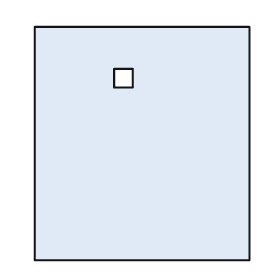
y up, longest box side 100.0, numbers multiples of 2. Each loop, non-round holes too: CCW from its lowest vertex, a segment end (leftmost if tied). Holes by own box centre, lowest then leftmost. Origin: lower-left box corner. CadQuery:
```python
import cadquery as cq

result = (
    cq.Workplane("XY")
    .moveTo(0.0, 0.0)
    .lineTo(92.0, 0.0)
    .lineTo(92.0, 100.0)
    .lineTo(0.0, 100.0)
    .close()
    .moveTo(34.0, 74.0)
    .lineTo(42.0, 74.0)
    .lineTo(42.0, 82.0)
    .lineTo(34.0, 82.0)
    .close()
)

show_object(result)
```